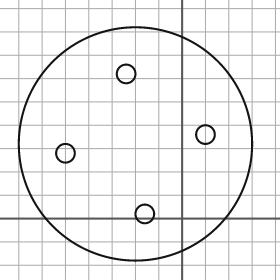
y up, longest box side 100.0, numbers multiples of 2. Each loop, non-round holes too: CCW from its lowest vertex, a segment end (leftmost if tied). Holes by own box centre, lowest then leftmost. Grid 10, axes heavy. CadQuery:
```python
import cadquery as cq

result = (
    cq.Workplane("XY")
    .moveTo(-20.0, 32.0)
    .circle(50.0)
    .moveTo(-16.0, 2.0)
    .circle(4.0)
    .moveTo(-50.0, 28.0)
    .circle(4.0)
    .moveTo(10.0, 36.0)
    .circle(4.0)
    .moveTo(-24.0, 62.0)
    .circle(4.0)
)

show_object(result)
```